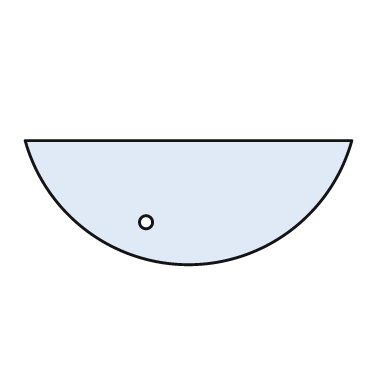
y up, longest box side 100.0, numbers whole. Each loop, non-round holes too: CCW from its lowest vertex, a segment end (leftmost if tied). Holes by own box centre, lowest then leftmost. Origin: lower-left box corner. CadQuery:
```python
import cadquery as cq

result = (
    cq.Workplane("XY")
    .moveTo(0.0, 38.0)
    .threePointArc((50.0, 0.0), (100.0, 38.0))
    .close()
    .moveTo(37.0, 13.0)
    .circle(2.0)
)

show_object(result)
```